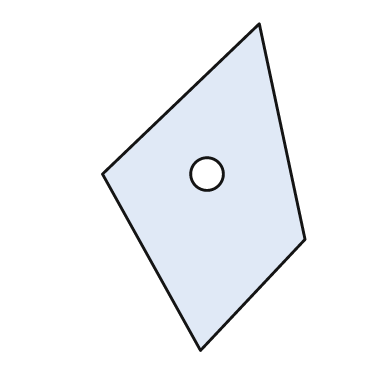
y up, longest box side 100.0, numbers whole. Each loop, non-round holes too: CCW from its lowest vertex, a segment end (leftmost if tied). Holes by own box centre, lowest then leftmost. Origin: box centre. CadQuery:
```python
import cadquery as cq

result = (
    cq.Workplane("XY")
    .moveTo(-1.0, -50.0)
    .lineTo(31.0, -16.0)
    .lineTo(17.0, 50.0)
    .lineTo(-31.0, 4.0)
    .close()
    .moveTo(1.0, 4.0)
    .circle(5.0)
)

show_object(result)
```